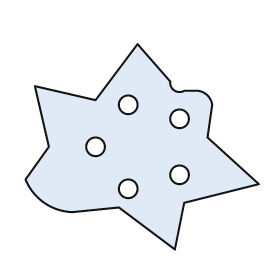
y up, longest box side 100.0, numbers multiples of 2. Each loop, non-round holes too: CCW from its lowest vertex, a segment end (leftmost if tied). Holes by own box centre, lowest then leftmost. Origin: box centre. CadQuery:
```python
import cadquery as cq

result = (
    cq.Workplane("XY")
    .moveTo(14.0, -44.0)
    .lineTo(18.0, -24.0)
    .lineTo(50.0, -16.0)
    .lineTo(28.0, 4.0)
    .lineTo(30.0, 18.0)
    .threePointArc((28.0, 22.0), (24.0, 24.0))
    .lineTo(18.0, 24.0)
    .threePointArc((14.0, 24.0), (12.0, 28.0))
    .lineTo(-2.0, 44.0)
    .lineTo(-20.0, 20.0)
    .lineTo(-46.0, 26.0)
    .lineTo(-40.0, 0.0)
    .lineTo(-50.0, -14.0)
    .threePointArc((-42.0, -24.0), (-30.0, -28.0))
    .lineTo(-10.0, -26.0)
    .close()
    .moveTo(-6.0, -18.0)
    .circle(4.0)
    .moveTo(16.0, -12.0)
    .circle(4.0)
    .moveTo(-20.0, 0.0)
    .circle(4.0)
    .moveTo(16.0, 12.0)
    .circle(4.0)
    .moveTo(-6.0, 18.0)
    .circle(4.0)
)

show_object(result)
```